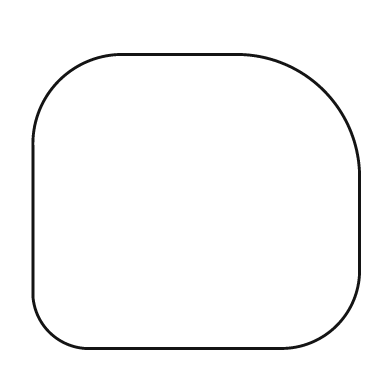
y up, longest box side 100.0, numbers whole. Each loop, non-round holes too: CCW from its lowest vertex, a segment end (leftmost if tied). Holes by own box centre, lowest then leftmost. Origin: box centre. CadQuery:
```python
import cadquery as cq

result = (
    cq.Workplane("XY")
    .moveTo(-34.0, -45.0)
    .lineTo(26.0, -45.0)
    .threePointArc((43.0, -38.0), (50.0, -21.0))
    .lineTo(50.0, 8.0)
    .threePointArc((39.0, 34.0), (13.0, 45.0))
    .lineTo(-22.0, 45.0)
    .threePointArc((-42.0, 37.0), (-50.0, 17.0))
    .lineTo(-50.0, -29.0)
    .threePointArc((-45.0, -40.0), (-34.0, -45.0))
    .close()
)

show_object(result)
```